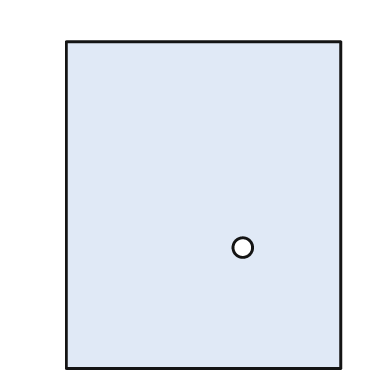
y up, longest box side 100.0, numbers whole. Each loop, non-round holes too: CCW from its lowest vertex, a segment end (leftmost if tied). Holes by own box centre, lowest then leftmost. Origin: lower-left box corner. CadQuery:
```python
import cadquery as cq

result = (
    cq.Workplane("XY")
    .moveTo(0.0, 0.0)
    .lineTo(84.0, 0.0)
    .lineTo(84.0, 100.0)
    .lineTo(0.0, 100.0)
    .close()
    .moveTo(54.0, 37.0)
    .circle(3.0)
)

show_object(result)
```